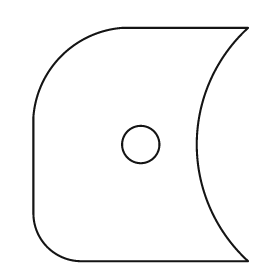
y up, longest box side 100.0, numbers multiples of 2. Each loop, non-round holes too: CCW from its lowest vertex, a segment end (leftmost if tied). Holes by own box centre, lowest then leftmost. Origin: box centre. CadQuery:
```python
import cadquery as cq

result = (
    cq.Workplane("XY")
    .moveTo(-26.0, -50.0)
    .lineTo(46.0, -50.0)
    .threePointArc((24.0, 0.0), (46.0, 50.0))
    .lineTo(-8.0, 50.0)
    .threePointArc((-34.0, 38.0), (-46.0, 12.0))
    .lineTo(-46.0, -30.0)
    .threePointArc((-40.0, -44.0), (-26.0, -50.0))
    .close()
    .moveTo(0.0, 0.0)
    .circle(8.0)
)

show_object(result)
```